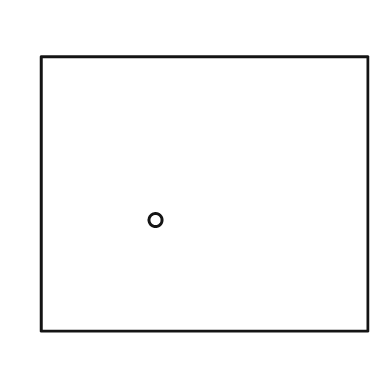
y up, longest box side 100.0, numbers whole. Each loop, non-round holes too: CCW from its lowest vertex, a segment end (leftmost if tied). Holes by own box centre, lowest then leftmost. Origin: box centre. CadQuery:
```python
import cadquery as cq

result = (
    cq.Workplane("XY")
    .moveTo(-50.0, -42.0)
    .lineTo(50.0, -42.0)
    .lineTo(50.0, 42.0)
    .lineTo(-50.0, 42.0)
    .close()
    .moveTo(-15.0, -8.0)
    .circle(2.0)
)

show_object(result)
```